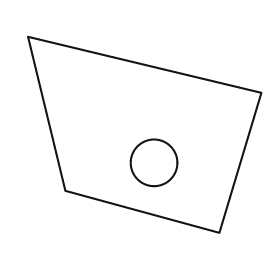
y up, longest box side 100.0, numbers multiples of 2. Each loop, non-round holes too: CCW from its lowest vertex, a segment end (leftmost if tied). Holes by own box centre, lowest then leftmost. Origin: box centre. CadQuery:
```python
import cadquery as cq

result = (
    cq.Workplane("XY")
    .moveTo(32.0, -42.0)
    .lineTo(50.0, 18.0)
    .lineTo(-50.0, 42.0)
    .lineTo(-34.0, -24.0)
    .close()
    .moveTo(4.0, -12.0)
    .circle(10.0)
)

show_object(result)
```